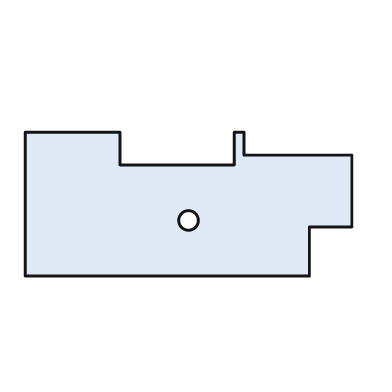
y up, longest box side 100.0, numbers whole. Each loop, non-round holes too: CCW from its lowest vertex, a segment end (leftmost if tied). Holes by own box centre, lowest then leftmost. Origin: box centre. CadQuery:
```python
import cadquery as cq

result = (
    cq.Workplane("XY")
    .moveTo(-50.0, -22.0)
    .lineTo(37.0, -22.0)
    .lineTo(37.0, -7.0)
    .lineTo(50.0, -7.0)
    .lineTo(50.0, 15.0)
    .lineTo(17.0, 15.0)
    .lineTo(17.0, 22.0)
    .lineTo(14.0, 22.0)
    .lineTo(14.0, 12.0)
    .lineTo(-21.0, 12.0)
    .lineTo(-21.0, 22.0)
    .lineTo(-50.0, 22.0)
    .close()
    .moveTo(0.0, -5.0)
    .circle(3.0)
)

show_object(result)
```